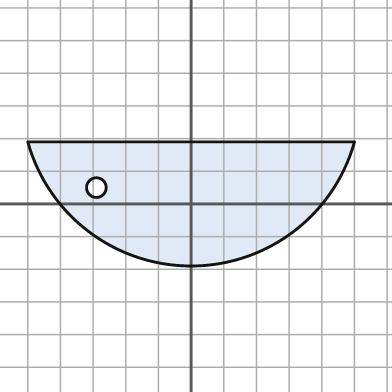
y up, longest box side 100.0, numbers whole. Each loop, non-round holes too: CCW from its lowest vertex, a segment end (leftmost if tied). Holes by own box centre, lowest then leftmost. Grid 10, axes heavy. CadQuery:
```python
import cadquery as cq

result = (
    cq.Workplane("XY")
    .moveTo(-50.0, 19.0)
    .threePointArc((0.0, -19.0), (50.0, 19.0))
    .close()
    .moveTo(-29.0, 5.0)
    .circle(3.0)
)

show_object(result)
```